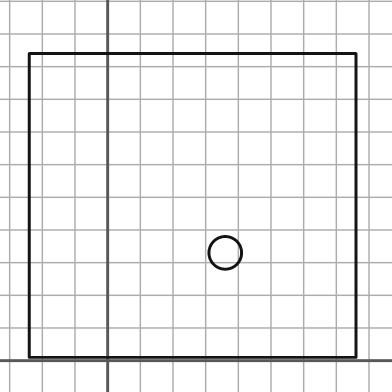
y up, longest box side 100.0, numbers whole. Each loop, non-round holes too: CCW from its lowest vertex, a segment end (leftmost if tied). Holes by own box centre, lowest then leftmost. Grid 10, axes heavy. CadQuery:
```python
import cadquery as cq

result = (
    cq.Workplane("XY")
    .moveTo(-24.0, 1.0)
    .lineTo(76.0, 1.0)
    .lineTo(76.0, 94.0)
    .lineTo(-24.0, 94.0)
    .close()
    .moveTo(36.0, 33.0)
    .circle(5.0)
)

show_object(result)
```